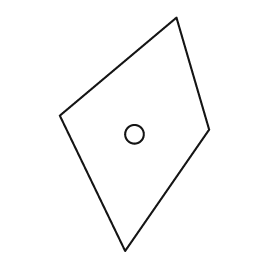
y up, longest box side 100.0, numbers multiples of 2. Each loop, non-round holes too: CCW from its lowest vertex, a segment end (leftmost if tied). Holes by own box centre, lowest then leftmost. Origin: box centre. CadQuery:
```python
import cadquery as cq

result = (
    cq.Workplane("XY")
    .moveTo(-4.0, -50.0)
    .lineTo(32.0, 2.0)
    .lineTo(18.0, 50.0)
    .lineTo(-32.0, 8.0)
    .close()
    .moveTo(0.0, 0.0)
    .circle(4.0)
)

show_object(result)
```